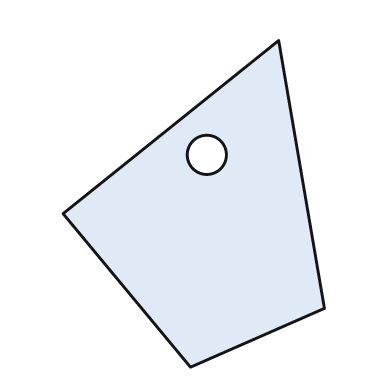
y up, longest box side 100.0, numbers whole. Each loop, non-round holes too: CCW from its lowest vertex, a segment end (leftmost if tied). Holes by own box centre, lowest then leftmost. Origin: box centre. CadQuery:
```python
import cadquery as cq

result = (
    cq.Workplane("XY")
    .moveTo(-1.0, -50.0)
    .lineTo(40.0, -32.0)
    .lineTo(26.0, 50.0)
    .lineTo(-40.0, -3.0)
    .close()
    .moveTo(4.0, 15.0)
    .circle(6.0)
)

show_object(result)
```